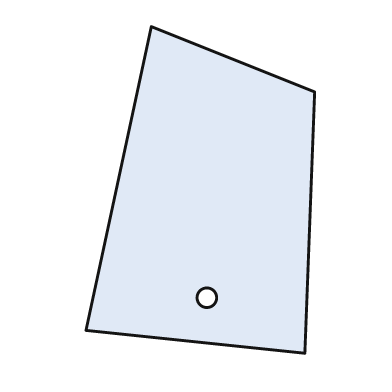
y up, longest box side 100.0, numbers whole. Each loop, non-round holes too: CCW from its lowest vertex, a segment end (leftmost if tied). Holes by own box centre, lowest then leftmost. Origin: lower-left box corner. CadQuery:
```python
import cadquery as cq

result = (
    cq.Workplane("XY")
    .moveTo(67.0, 0.0)
    .lineTo(70.0, 80.0)
    .lineTo(20.0, 100.0)
    .lineTo(0.0, 7.0)
    .close()
    .moveTo(37.0, 17.0)
    .circle(3.0)
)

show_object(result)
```